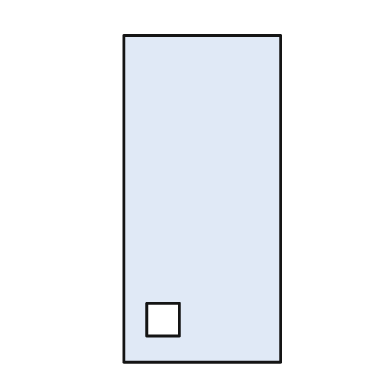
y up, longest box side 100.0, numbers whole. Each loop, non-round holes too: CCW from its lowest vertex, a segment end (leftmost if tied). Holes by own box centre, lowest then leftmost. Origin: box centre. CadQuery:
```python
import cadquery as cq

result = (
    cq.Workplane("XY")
    .moveTo(-24.0, -50.0)
    .lineTo(24.0, -50.0)
    .lineTo(24.0, 50.0)
    .lineTo(-24.0, 50.0)
    .close()
    .moveTo(-17.0, -42.0)
    .lineTo(-7.0, -42.0)
    .lineTo(-7.0, -32.0)
    .lineTo(-17.0, -32.0)
    .close()
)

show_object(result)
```